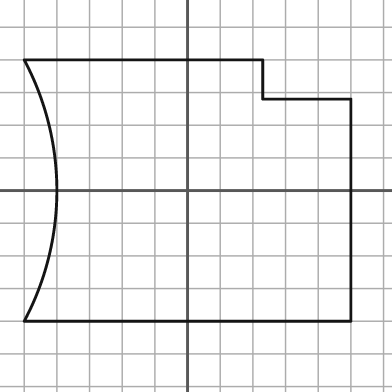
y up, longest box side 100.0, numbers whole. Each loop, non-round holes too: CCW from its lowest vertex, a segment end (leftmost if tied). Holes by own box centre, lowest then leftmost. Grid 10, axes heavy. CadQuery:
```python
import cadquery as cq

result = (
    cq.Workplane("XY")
    .moveTo(-50.0, -40.0)
    .lineTo(50.0, -40.0)
    .lineTo(50.0, 28.0)
    .lineTo(23.0, 28.0)
    .lineTo(23.0, 40.0)
    .lineTo(-50.0, 40.0)
    .threePointArc((-40.0, 0.0), (-50.0, -40.0))
    .close()
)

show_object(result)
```